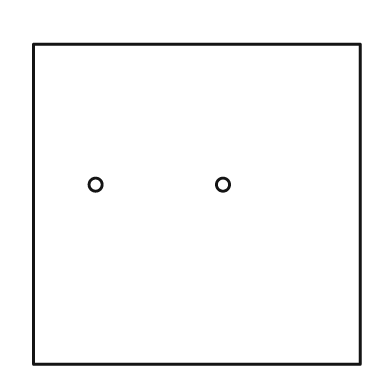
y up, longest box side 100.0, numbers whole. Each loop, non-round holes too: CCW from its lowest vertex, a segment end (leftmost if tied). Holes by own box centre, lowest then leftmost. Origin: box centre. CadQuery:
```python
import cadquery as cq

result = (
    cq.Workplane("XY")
    .moveTo(-50.0, -49.0)
    .lineTo(50.0, -49.0)
    .lineTo(50.0, 49.0)
    .lineTo(-50.0, 49.0)
    .close()
    .moveTo(-31.0, 6.0)
    .circle(2.0)
    .moveTo(8.0, 6.0)
    .circle(2.0)
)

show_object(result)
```